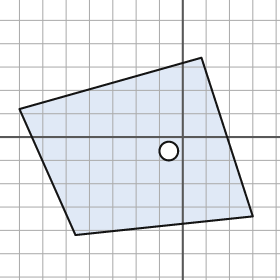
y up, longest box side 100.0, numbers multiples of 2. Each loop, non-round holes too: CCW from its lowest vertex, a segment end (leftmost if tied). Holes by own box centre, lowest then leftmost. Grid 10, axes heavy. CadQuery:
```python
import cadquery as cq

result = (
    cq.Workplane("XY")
    .moveTo(-46.0, -42.0)
    .lineTo(30.0, -34.0)
    .lineTo(8.0, 34.0)
    .lineTo(-70.0, 12.0)
    .close()
    .moveTo(-6.0, -6.0)
    .circle(4.0)
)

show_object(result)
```